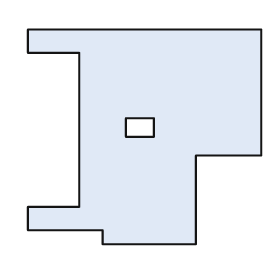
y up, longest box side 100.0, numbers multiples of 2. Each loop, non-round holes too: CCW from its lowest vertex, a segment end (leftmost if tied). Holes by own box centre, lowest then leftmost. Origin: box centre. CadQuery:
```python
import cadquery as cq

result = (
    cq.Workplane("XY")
    .moveTo(-18.0, -46.0)
    .lineTo(22.0, -46.0)
    .lineTo(22.0, -8.0)
    .lineTo(50.0, -8.0)
    .lineTo(50.0, 46.0)
    .lineTo(-50.0, 46.0)
    .lineTo(-50.0, 36.0)
    .lineTo(-28.0, 36.0)
    .lineTo(-28.0, -30.0)
    .lineTo(-50.0, -30.0)
    .lineTo(-50.0, -40.0)
    .lineTo(-18.0, -40.0)
    .close()
    .moveTo(-8.0, 0.0)
    .lineTo(4.0, 0.0)
    .lineTo(4.0, 8.0)
    .lineTo(-8.0, 8.0)
    .close()
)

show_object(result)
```